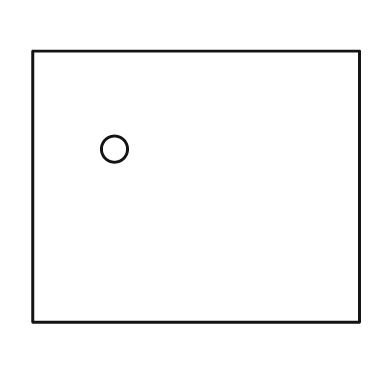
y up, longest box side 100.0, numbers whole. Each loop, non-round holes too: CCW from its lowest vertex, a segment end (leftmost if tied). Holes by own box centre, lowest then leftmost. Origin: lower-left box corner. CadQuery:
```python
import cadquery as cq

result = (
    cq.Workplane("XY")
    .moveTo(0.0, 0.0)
    .lineTo(100.0, 0.0)
    .lineTo(100.0, 83.0)
    .lineTo(0.0, 83.0)
    .close()
    .moveTo(25.0, 53.0)
    .circle(4.0)
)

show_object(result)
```